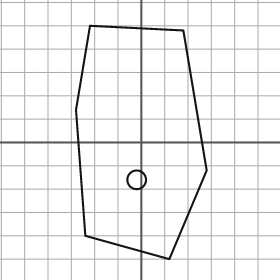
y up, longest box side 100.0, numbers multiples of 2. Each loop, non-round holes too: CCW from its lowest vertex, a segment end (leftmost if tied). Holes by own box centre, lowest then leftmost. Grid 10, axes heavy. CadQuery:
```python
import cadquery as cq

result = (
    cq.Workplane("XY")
    .moveTo(12.0, -50.0)
    .lineTo(28.0, -12.0)
    .lineTo(18.0, 48.0)
    .lineTo(-22.0, 50.0)
    .lineTo(-28.0, 14.0)
    .lineTo(-24.0, -40.0)
    .close()
    .moveTo(-2.0, -16.0)
    .circle(4.0)
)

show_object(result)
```